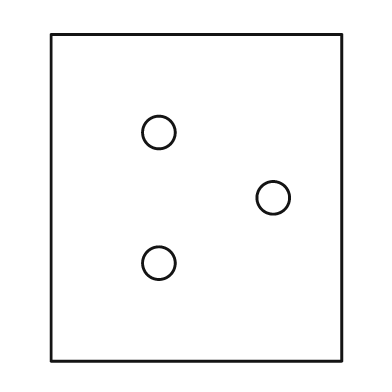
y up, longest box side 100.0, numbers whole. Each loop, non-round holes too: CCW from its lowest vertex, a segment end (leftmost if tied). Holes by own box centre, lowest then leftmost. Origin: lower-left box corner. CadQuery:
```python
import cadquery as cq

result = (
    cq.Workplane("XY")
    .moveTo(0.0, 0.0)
    .lineTo(89.0, 0.0)
    .lineTo(89.0, 100.0)
    .lineTo(0.0, 100.0)
    .close()
    .moveTo(33.0, 30.0)
    .circle(5.0)
    .moveTo(68.0, 50.0)
    .circle(5.0)
    .moveTo(33.0, 70.0)
    .circle(5.0)
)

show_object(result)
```